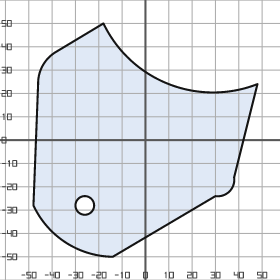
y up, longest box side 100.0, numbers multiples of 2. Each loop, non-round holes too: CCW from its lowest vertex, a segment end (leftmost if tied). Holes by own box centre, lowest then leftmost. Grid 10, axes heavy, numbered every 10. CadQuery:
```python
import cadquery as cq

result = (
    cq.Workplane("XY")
    .moveTo(-14.0, -50.0)
    .lineTo(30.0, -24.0)
    .threePointArc((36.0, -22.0), (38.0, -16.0))
    .lineTo(48.0, 24.0)
    .threePointArc((10.0, 24.0), (-18.0, 50.0))
    .lineTo(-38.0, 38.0)
    .threePointArc((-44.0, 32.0), (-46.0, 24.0))
    .lineTo(-48.0, -28.0)
    .threePointArc((-34.0, -44.0), (-14.0, -50.0))
    .close()
    .moveTo(-26.0, -28.0)
    .circle(4.0)
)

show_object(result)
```